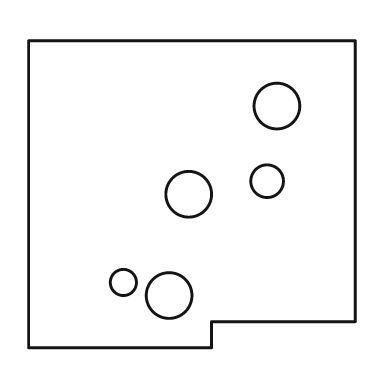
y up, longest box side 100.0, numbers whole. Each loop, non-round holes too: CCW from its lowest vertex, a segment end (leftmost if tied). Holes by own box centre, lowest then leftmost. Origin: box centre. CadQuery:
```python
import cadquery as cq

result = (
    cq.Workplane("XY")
    .moveTo(-50.0, -47.0)
    .lineTo(6.0, -47.0)
    .lineTo(6.0, -39.0)
    .lineTo(50.0, -39.0)
    .lineTo(50.0, 47.0)
    .lineTo(-50.0, 47.0)
    .close()
    .moveTo(-7.0, -31.0)
    .circle(7.0)
    .moveTo(-21.0, -27.0)
    .circle(4.0)
    .moveTo(-1.0, 0.0)
    .circle(7.0)
    .moveTo(23.0, 4.0)
    .circle(5.0)
    .moveTo(26.0, 27.0)
    .circle(7.0)
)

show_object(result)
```